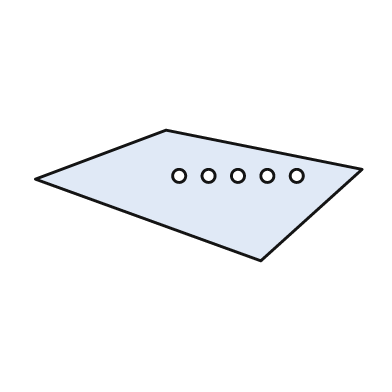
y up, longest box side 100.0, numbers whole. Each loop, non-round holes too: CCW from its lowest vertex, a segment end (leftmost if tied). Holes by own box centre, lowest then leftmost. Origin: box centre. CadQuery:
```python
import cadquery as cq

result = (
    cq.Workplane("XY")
    .moveTo(19.0, -20.0)
    .lineTo(50.0, 8.0)
    .lineTo(-10.0, 20.0)
    .lineTo(-50.0, 5.0)
    .close()
    .moveTo(-6.0, 6.0)
    .circle(2.0)
    .moveTo(3.0, 6.0)
    .circle(2.0)
    .moveTo(12.0, 6.0)
    .circle(2.0)
    .moveTo(21.0, 6.0)
    .circle(2.0)
    .moveTo(30.0, 6.0)
    .circle(2.0)
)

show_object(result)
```